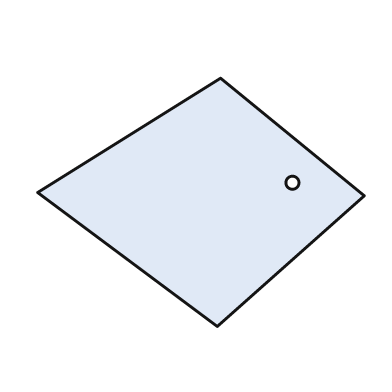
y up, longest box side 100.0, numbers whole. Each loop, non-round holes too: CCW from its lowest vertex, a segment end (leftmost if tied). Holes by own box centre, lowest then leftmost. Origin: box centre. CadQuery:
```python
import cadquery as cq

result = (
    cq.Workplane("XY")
    .moveTo(5.0, -38.0)
    .lineTo(50.0, 2.0)
    .lineTo(6.0, 38.0)
    .lineTo(-50.0, 3.0)
    .close()
    .moveTo(28.0, 6.0)
    .circle(2.0)
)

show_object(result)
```